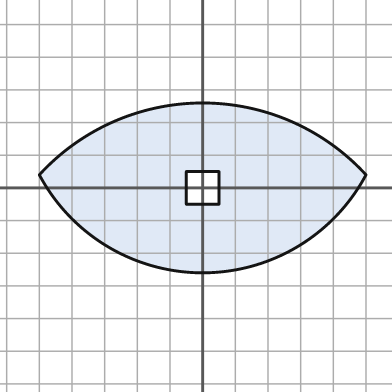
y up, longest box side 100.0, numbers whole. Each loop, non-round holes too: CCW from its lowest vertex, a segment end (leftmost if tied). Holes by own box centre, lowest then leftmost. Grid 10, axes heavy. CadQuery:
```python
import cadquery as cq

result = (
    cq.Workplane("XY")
    .moveTo(-50.0, 4.0)
    .threePointArc((0.0, -26.0), (50.0, 4.0))
    .threePointArc((0.0, 26.0), (-50.0, 4.0))
    .close()
    .moveTo(-5.0, -5.0)
    .lineTo(5.0, -5.0)
    .lineTo(5.0, 5.0)
    .lineTo(-5.0, 5.0)
    .close()
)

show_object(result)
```